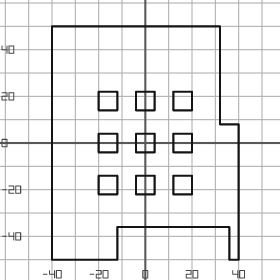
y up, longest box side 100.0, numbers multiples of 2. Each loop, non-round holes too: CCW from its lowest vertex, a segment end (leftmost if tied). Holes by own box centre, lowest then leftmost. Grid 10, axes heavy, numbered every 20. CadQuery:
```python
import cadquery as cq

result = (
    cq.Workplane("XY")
    .moveTo(-40.0, -50.0)
    .lineTo(-12.0, -50.0)
    .lineTo(-12.0, -36.0)
    .lineTo(36.0, -36.0)
    .lineTo(36.0, -50.0)
    .lineTo(40.0, -50.0)
    .lineTo(40.0, 8.0)
    .lineTo(32.0, 8.0)
    .lineTo(32.0, 50.0)
    .lineTo(-40.0, 50.0)
    .close()
    .moveTo(-20.0, -22.0)
    .lineTo(-12.0, -22.0)
    .lineTo(-12.0, -14.0)
    .lineTo(-20.0, -14.0)
    .close()
    .moveTo(-4.0, -22.0)
    .lineTo(4.0, -22.0)
    .lineTo(4.0, -14.0)
    .lineTo(-4.0, -14.0)
    .close()
    .moveTo(12.0, -22.0)
    .lineTo(20.0, -22.0)
    .lineTo(20.0, -14.0)
    .lineTo(12.0, -14.0)
    .close()
    .moveTo(-20.0, -4.0)
    .lineTo(-12.0, -4.0)
    .lineTo(-12.0, 4.0)
    .lineTo(-20.0, 4.0)
    .close()
    .moveTo(-4.0, -4.0)
    .lineTo(4.0, -4.0)
    .lineTo(4.0, 4.0)
    .lineTo(-4.0, 4.0)
    .close()
    .moveTo(12.0, -4.0)
    .lineTo(20.0, -4.0)
    .lineTo(20.0, 4.0)
    .lineTo(12.0, 4.0)
    .close()
    .moveTo(-20.0, 14.0)
    .lineTo(-12.0, 14.0)
    .lineTo(-12.0, 22.0)
    .lineTo(-20.0, 22.0)
    .close()
    .moveTo(-4.0, 14.0)
    .lineTo(4.0, 14.0)
    .lineTo(4.0, 22.0)
    .lineTo(-4.0, 22.0)
    .close()
    .moveTo(12.0, 14.0)
    .lineTo(20.0, 14.0)
    .lineTo(20.0, 22.0)
    .lineTo(12.0, 22.0)
    .close()
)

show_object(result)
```